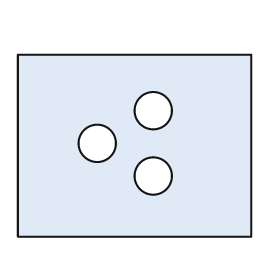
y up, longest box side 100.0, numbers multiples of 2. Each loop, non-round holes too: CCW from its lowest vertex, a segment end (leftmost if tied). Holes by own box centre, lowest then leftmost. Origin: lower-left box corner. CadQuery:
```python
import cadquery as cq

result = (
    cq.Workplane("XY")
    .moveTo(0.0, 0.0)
    .lineTo(100.0, 0.0)
    .lineTo(100.0, 78.0)
    .lineTo(0.0, 78.0)
    .close()
    .moveTo(58.0, 26.0)
    .circle(8.0)
    .moveTo(34.0, 40.0)
    .circle(8.0)
    .moveTo(58.0, 54.0)
    .circle(8.0)
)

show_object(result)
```